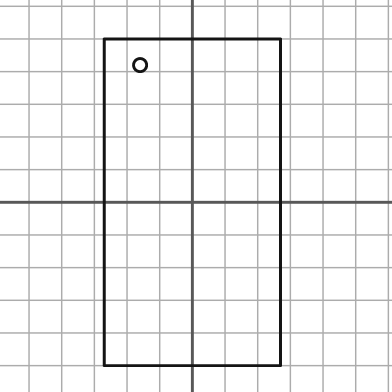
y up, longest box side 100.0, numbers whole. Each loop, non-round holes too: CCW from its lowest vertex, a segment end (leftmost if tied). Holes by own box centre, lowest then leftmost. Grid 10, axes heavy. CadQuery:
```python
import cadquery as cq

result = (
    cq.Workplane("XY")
    .moveTo(-27.0, -50.0)
    .lineTo(27.0, -50.0)
    .lineTo(27.0, 50.0)
    .lineTo(-27.0, 50.0)
    .close()
    .moveTo(-16.0, 42.0)
    .circle(2.0)
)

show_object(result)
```